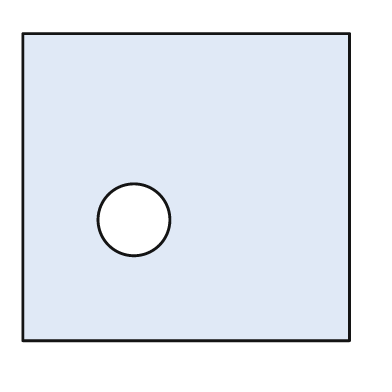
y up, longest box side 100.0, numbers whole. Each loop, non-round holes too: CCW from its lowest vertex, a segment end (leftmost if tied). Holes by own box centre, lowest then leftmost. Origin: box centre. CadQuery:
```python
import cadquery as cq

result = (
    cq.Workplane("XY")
    .moveTo(-50.0, -47.0)
    .lineTo(50.0, -47.0)
    .lineTo(50.0, 47.0)
    .lineTo(-50.0, 47.0)
    .close()
    .moveTo(-16.0, -10.0)
    .circle(11.0)
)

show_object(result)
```